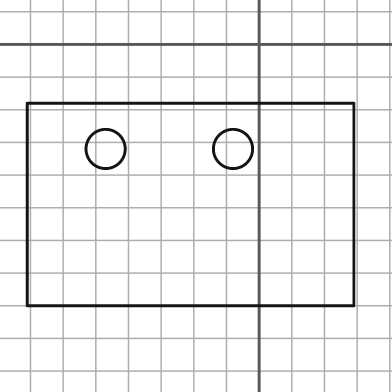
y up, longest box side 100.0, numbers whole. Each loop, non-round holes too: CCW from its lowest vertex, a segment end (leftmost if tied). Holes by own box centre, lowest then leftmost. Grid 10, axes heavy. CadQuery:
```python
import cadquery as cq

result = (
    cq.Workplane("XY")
    .moveTo(-71.0, -80.0)
    .lineTo(29.0, -80.0)
    .lineTo(29.0, -18.0)
    .lineTo(-71.0, -18.0)
    .close()
    .moveTo(-47.0, -32.0)
    .circle(6.0)
    .moveTo(-8.0, -32.0)
    .circle(6.0)
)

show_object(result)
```